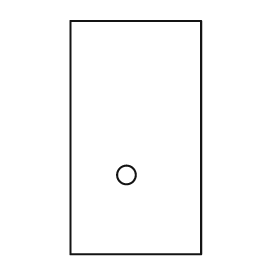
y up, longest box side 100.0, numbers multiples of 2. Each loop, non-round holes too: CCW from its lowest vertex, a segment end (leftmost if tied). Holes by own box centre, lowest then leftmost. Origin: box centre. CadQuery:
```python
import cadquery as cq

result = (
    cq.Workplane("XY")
    .moveTo(-28.0, -50.0)
    .lineTo(28.0, -50.0)
    .lineTo(28.0, 50.0)
    .lineTo(-28.0, 50.0)
    .close()
    .moveTo(-4.0, -16.0)
    .circle(4.0)
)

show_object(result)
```